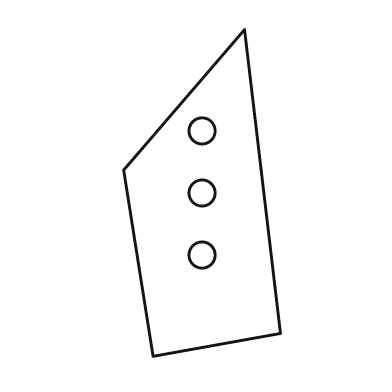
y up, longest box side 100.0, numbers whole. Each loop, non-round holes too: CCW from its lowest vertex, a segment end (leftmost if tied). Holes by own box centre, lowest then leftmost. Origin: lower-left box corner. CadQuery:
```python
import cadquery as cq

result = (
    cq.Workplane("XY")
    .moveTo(9.0, 0.0)
    .lineTo(48.0, 7.0)
    .lineTo(37.0, 100.0)
    .lineTo(0.0, 57.0)
    .close()
    .moveTo(24.0, 31.0)
    .circle(4.0)
    .moveTo(24.0, 50.0)
    .circle(4.0)
    .moveTo(24.0, 69.0)
    .circle(4.0)
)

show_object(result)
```